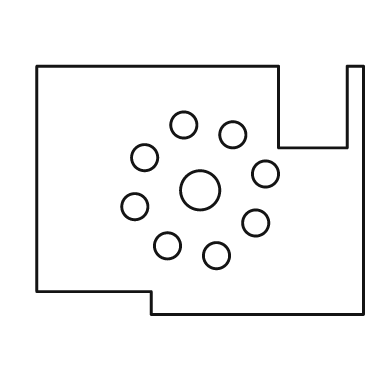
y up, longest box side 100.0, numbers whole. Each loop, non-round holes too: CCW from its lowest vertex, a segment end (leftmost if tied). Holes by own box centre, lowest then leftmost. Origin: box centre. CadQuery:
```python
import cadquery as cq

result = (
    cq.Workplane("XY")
    .moveTo(-15.0, -38.0)
    .lineTo(50.0, -38.0)
    .lineTo(50.0, 38.0)
    .lineTo(45.0, 38.0)
    .lineTo(45.0, 13.0)
    .lineTo(24.0, 13.0)
    .lineTo(24.0, 38.0)
    .lineTo(-50.0, 38.0)
    .lineTo(-50.0, -31.0)
    .lineTo(-15.0, -31.0)
    .close()
    .moveTo(5.0, -20.0)
    .circle(4.0)
    .moveTo(-10.0, -17.0)
    .circle(4.0)
    .moveTo(17.0, -10.0)
    .circle(4.0)
    .moveTo(-20.0, -5.0)
    .circle(4.0)
    .moveTo(0.0, 0.0)
    .circle(6.0)
    .moveTo(20.0, 5.0)
    .circle(4.0)
    .moveTo(-17.0, 10.0)
    .circle(4.0)
    .moveTo(10.0, 17.0)
    .circle(4.0)
    .moveTo(-5.0, 20.0)
    .circle(4.0)
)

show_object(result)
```